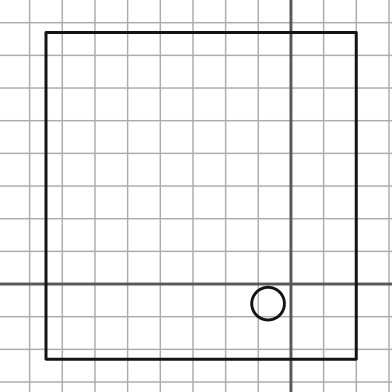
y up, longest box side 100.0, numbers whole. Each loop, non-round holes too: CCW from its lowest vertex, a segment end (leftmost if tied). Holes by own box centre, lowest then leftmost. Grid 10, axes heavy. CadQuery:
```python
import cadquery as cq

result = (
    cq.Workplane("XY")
    .moveTo(-75.0, -23.0)
    .lineTo(20.0, -23.0)
    .lineTo(20.0, 77.0)
    .lineTo(-75.0, 77.0)
    .close()
    .moveTo(-7.0, -6.0)
    .circle(5.0)
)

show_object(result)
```